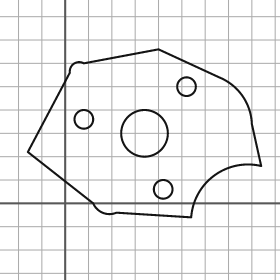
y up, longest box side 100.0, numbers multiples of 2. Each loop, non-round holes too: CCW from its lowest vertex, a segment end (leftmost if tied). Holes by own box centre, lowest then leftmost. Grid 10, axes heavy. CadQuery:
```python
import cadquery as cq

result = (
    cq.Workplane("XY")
    .moveTo(54.0, -6.0)
    .threePointArc((64.0, 12.0), (84.0, 16.0))
    .lineTo(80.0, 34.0)
    .threePointArc((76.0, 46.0), (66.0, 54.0))
    .lineTo(40.0, 66.0)
    .lineTo(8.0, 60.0)
    .threePointArc((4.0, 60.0), (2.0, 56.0))
    .lineTo(-16.0, 22.0)
    .lineTo(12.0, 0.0)
    .threePointArc((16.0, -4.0), (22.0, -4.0))
    .close()
    .moveTo(42.0, 6.0)
    .circle(4.0)
    .moveTo(34.0, 30.0)
    .circle(10.0)
    .moveTo(8.0, 36.0)
    .circle(4.0)
    .moveTo(52.0, 50.0)
    .circle(4.0)
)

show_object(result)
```